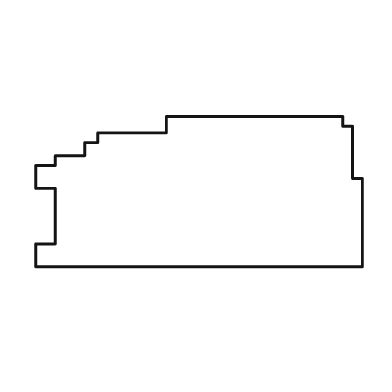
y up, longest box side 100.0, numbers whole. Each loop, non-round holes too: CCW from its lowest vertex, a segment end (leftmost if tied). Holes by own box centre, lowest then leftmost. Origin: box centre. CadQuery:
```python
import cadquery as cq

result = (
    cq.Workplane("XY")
    .moveTo(-50.0, -23.0)
    .lineTo(50.0, -23.0)
    .lineTo(50.0, 4.0)
    .lineTo(47.0, 4.0)
    .lineTo(47.0, 20.0)
    .lineTo(44.0, 20.0)
    .lineTo(44.0, 23.0)
    .lineTo(-10.0, 23.0)
    .lineTo(-10.0, 18.0)
    .lineTo(-31.0, 18.0)
    .lineTo(-31.0, 15.0)
    .lineTo(-35.0, 15.0)
    .lineTo(-35.0, 11.0)
    .lineTo(-44.0, 11.0)
    .lineTo(-44.0, 8.0)
    .lineTo(-50.0, 8.0)
    .lineTo(-50.0, 1.0)
    .lineTo(-44.0, 1.0)
    .lineTo(-44.0, -16.0)
    .lineTo(-50.0, -16.0)
    .close()
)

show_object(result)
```